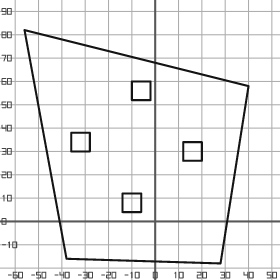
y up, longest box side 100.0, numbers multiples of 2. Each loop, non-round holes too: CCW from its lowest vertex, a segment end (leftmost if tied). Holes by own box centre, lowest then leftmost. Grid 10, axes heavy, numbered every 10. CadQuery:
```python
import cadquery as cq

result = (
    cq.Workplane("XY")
    .moveTo(28.0, -18.0)
    .lineTo(40.0, 58.0)
    .lineTo(-56.0, 82.0)
    .lineTo(-38.0, -16.0)
    .close()
    .moveTo(-14.0, 4.0)
    .lineTo(-6.0, 4.0)
    .lineTo(-6.0, 12.0)
    .lineTo(-14.0, 12.0)
    .close()
    .moveTo(12.0, 26.0)
    .lineTo(20.0, 26.0)
    .lineTo(20.0, 34.0)
    .lineTo(12.0, 34.0)
    .close()
    .moveTo(-36.0, 30.0)
    .lineTo(-28.0, 30.0)
    .lineTo(-28.0, 38.0)
    .lineTo(-36.0, 38.0)
    .close()
    .moveTo(-10.0, 52.0)
    .lineTo(-2.0, 52.0)
    .lineTo(-2.0, 60.0)
    .lineTo(-10.0, 60.0)
    .close()
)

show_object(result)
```